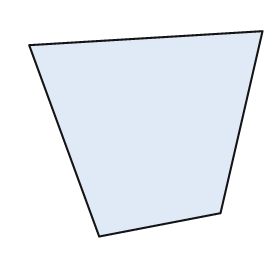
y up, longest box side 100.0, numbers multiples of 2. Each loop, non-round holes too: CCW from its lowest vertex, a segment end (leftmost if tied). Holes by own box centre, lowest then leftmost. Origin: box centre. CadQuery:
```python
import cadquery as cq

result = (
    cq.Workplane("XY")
    .moveTo(-20.0, -44.0)
    .lineTo(32.0, -34.0)
    .lineTo(50.0, 44.0)
    .lineTo(-50.0, 38.0)
    .close()
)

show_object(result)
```